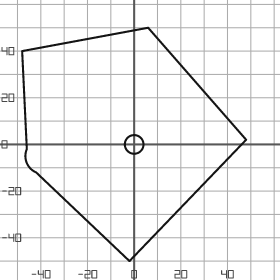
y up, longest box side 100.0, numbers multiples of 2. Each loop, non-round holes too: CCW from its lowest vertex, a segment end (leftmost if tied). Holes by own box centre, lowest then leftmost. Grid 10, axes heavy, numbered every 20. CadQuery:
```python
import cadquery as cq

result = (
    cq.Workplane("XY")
    .moveTo(-2.0, -50.0)
    .lineTo(48.0, 2.0)
    .lineTo(6.0, 50.0)
    .lineTo(-48.0, 40.0)
    .lineTo(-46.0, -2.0)
    .threePointArc((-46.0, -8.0), (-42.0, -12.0))
    .close()
    .moveTo(0.0, 0.0)
    .circle(4.0)
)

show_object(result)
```